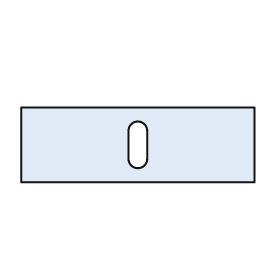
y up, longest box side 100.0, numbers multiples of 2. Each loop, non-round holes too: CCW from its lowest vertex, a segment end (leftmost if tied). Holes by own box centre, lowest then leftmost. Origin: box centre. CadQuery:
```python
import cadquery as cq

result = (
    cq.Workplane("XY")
    .moveTo(-50.0, -16.0)
    .lineTo(50.0, -16.0)
    .lineTo(50.0, 16.0)
    .lineTo(-50.0, 16.0)
    .close()
    .moveTo(-4.0, -6.0)
    .threePointArc((0.0, -10.0), (4.0, -6.0))
    .lineTo(4.0, 6.0)
    .threePointArc((0.0, 10.0), (-4.0, 6.0))
    .close()
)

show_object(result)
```